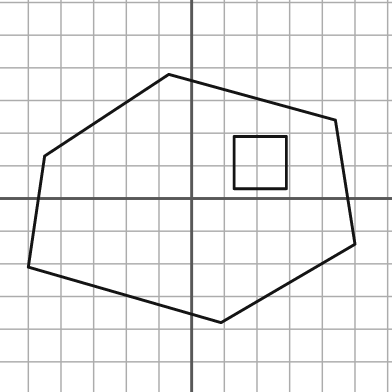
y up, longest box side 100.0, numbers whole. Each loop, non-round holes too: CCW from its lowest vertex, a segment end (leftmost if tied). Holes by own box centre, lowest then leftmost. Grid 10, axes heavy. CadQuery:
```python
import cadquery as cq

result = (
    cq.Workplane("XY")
    .moveTo(9.0, -38.0)
    .lineTo(50.0, -14.0)
    .lineTo(44.0, 24.0)
    .lineTo(-7.0, 38.0)
    .lineTo(-45.0, 13.0)
    .lineTo(-50.0, -21.0)
    .close()
    .moveTo(13.0, 3.0)
    .lineTo(29.0, 3.0)
    .lineTo(29.0, 19.0)
    .lineTo(13.0, 19.0)
    .close()
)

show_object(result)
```